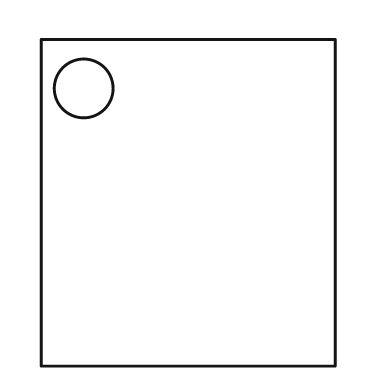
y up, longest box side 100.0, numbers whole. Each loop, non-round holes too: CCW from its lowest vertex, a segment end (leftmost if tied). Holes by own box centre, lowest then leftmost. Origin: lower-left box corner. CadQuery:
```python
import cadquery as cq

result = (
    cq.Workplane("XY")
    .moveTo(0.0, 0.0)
    .lineTo(90.0, 0.0)
    .lineTo(90.0, 100.0)
    .lineTo(0.0, 100.0)
    .close()
    .moveTo(13.0, 85.0)
    .circle(9.0)
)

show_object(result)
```